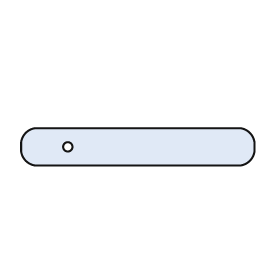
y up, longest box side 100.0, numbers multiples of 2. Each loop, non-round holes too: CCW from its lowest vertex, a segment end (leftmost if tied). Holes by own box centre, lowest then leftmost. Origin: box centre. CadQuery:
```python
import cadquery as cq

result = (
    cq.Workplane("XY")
    .moveTo(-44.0, -8.0)
    .lineTo(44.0, -8.0)
    .threePointArc((48.0, -6.0), (50.0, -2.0))
    .lineTo(50.0, 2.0)
    .threePointArc((48.0, 6.0), (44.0, 8.0))
    .lineTo(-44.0, 8.0)
    .threePointArc((-48.0, 6.0), (-50.0, 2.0))
    .lineTo(-50.0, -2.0)
    .threePointArc((-48.0, -6.0), (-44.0, -8.0))
    .close()
    .moveTo(-30.0, 0.0)
    .circle(2.0)
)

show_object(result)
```